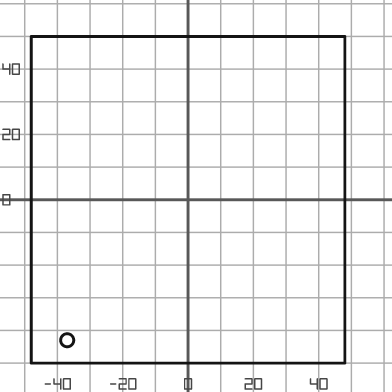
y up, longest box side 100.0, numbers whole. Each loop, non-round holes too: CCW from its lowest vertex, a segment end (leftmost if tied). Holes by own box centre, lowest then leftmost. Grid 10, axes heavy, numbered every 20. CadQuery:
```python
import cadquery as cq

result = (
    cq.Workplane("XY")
    .moveTo(-48.0, -50.0)
    .lineTo(48.0, -50.0)
    .lineTo(48.0, 50.0)
    .lineTo(-48.0, 50.0)
    .close()
    .moveTo(-37.0, -43.0)
    .circle(2.0)
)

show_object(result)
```